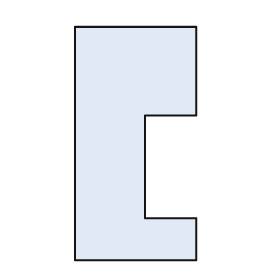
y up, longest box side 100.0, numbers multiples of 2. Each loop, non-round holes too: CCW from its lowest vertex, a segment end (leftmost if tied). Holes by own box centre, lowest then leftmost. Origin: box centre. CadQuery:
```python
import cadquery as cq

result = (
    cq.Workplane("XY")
    .moveTo(-26.0, -50.0)
    .lineTo(26.0, -50.0)
    .lineTo(26.0, -32.0)
    .lineTo(4.0, -32.0)
    .lineTo(4.0, 12.0)
    .lineTo(26.0, 12.0)
    .lineTo(26.0, 50.0)
    .lineTo(-26.0, 50.0)
    .close()
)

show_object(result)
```